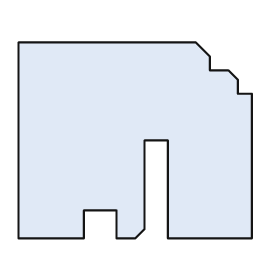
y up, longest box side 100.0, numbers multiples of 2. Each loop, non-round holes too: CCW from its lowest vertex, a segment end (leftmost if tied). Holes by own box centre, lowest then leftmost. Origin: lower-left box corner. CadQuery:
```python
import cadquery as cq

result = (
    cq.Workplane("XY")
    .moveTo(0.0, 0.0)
    .lineTo(28.0, 0.0)
    .lineTo(28.0, 12.0)
    .lineTo(42.0, 12.0)
    .lineTo(42.0, 0.0)
    .lineTo(50.0, 0.0)
    .lineTo(54.0, 4.0)
    .lineTo(54.0, 42.0)
    .lineTo(64.0, 42.0)
    .lineTo(64.0, 0.0)
    .lineTo(100.0, 0.0)
    .lineTo(100.0, 62.0)
    .lineTo(94.0, 62.0)
    .lineTo(94.0, 68.0)
    .lineTo(90.0, 72.0)
    .lineTo(82.0, 72.0)
    .lineTo(82.0, 78.0)
    .lineTo(76.0, 84.0)
    .lineTo(0.0, 84.0)
    .close()
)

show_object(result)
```